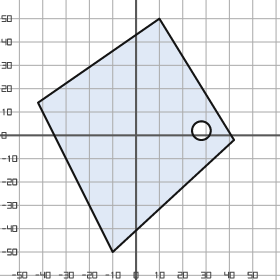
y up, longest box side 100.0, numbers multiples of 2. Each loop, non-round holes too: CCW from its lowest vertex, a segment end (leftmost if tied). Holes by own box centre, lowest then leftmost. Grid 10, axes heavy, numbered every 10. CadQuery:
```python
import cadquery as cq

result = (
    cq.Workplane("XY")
    .moveTo(-10.0, -50.0)
    .lineTo(42.0, -2.0)
    .lineTo(10.0, 50.0)
    .lineTo(-42.0, 14.0)
    .close()
    .moveTo(28.0, 2.0)
    .circle(4.0)
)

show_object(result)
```